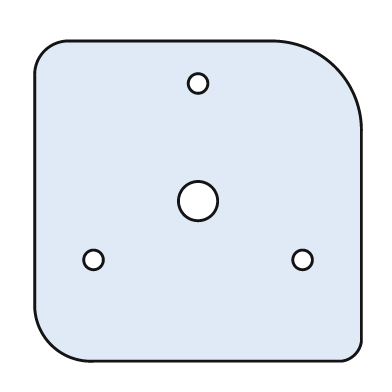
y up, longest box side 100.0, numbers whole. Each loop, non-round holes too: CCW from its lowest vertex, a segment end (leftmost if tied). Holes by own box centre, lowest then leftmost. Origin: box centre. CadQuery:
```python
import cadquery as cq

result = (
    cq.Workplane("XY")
    .moveTo(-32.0, -49.0)
    .lineTo(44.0, -49.0)
    .threePointArc((48.0, -47.0), (50.0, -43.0))
    .lineTo(50.0, 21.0)
    .threePointArc((42.0, 41.0), (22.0, 49.0))
    .lineTo(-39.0, 49.0)
    .threePointArc((-47.0, 46.0), (-50.0, 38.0))
    .lineTo(-50.0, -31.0)
    .threePointArc((-45.0, -44.0), (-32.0, -49.0))
    .close()
    .moveTo(-32.0, -18.0)
    .circle(3.0)
    .moveTo(32.0, -18.0)
    .circle(3.0)
    .moveTo(0.0, 0.0)
    .circle(6.0)
    .moveTo(0.0, 36.0)
    .circle(3.0)
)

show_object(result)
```